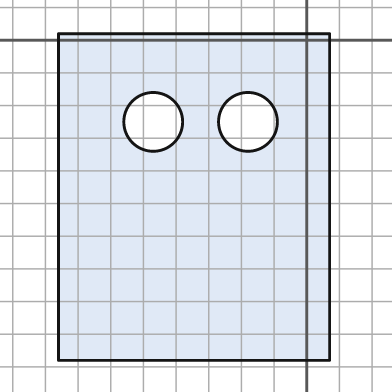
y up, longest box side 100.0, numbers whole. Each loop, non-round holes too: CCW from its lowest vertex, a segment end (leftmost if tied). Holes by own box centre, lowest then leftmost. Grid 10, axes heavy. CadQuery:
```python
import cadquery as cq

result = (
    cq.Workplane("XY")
    .moveTo(-76.0, -98.0)
    .lineTo(7.0, -98.0)
    .lineTo(7.0, 2.0)
    .lineTo(-76.0, 2.0)
    .close()
    .moveTo(-47.0, -25.0)
    .circle(9.0)
    .moveTo(-18.0, -25.0)
    .circle(9.0)
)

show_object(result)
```